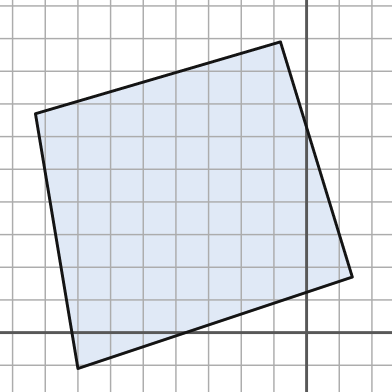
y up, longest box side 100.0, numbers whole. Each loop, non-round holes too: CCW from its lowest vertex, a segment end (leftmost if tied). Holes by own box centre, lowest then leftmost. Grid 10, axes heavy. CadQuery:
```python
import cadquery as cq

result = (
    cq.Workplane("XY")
    .moveTo(-70.0, -11.0)
    .lineTo(14.0, 17.0)
    .lineTo(-8.0, 89.0)
    .lineTo(-83.0, 67.0)
    .close()
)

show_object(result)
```